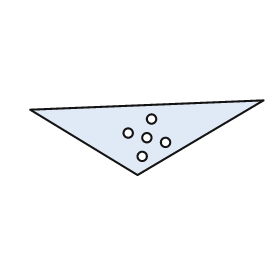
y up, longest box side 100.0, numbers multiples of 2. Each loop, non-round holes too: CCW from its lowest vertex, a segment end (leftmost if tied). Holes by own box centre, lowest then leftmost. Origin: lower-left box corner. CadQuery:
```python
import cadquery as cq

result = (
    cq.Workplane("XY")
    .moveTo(46.0, 0.0)
    .lineTo(100.0, 32.0)
    .lineTo(0.0, 28.0)
    .close()
    .moveTo(48.0, 8.0)
    .circle(2.0)
    .moveTo(58.0, 14.0)
    .circle(2.0)
    .moveTo(50.0, 16.0)
    .circle(2.0)
    .moveTo(42.0, 18.0)
    .circle(2.0)
    .moveTo(52.0, 24.0)
    .circle(2.0)
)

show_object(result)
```